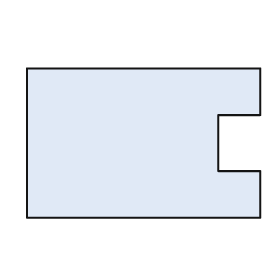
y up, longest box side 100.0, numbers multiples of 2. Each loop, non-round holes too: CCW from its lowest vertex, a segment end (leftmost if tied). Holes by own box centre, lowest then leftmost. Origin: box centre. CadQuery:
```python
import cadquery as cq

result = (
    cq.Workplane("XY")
    .moveTo(-50.0, -32.0)
    .lineTo(50.0, -32.0)
    .lineTo(50.0, -12.0)
    .lineTo(32.0, -12.0)
    .lineTo(32.0, 12.0)
    .lineTo(50.0, 12.0)
    .lineTo(50.0, 32.0)
    .lineTo(-50.0, 32.0)
    .close()
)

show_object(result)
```